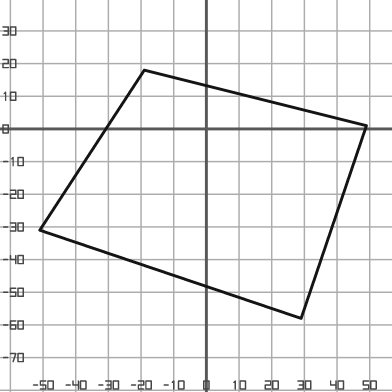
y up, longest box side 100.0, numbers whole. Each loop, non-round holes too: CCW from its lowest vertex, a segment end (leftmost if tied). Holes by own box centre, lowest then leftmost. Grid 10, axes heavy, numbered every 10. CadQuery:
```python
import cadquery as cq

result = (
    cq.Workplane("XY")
    .moveTo(29.0, -58.0)
    .lineTo(49.0, 1.0)
    .lineTo(-19.0, 18.0)
    .lineTo(-51.0, -31.0)
    .close()
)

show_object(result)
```